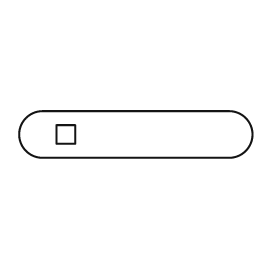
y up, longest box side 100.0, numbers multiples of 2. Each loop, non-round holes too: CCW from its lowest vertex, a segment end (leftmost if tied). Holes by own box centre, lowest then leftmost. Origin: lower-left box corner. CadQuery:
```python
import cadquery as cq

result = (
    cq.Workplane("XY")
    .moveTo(10.0, 0.0)
    .lineTo(90.0, 0.0)
    .threePointArc((100.0, 10.0), (90.0, 20.0))
    .lineTo(10.0, 20.0)
    .threePointArc((0.0, 10.0), (10.0, 0.0))
    .close()
    .moveTo(16.0, 6.0)
    .lineTo(24.0, 6.0)
    .lineTo(24.0, 14.0)
    .lineTo(16.0, 14.0)
    .close()
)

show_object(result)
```